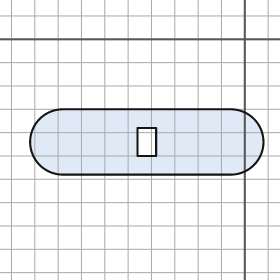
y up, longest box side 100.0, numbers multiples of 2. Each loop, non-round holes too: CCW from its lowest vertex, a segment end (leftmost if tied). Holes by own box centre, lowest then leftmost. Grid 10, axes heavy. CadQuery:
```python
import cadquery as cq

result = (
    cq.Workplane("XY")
    .moveTo(-78.0, -58.0)
    .lineTo(-6.0, -58.0)
    .threePointArc((8.0, -44.0), (-6.0, -30.0))
    .lineTo(-78.0, -30.0)
    .threePointArc((-92.0, -44.0), (-78.0, -58.0))
    .close()
    .moveTo(-46.0, -50.0)
    .lineTo(-38.0, -50.0)
    .lineTo(-38.0, -38.0)
    .lineTo(-46.0, -38.0)
    .close()
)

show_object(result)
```